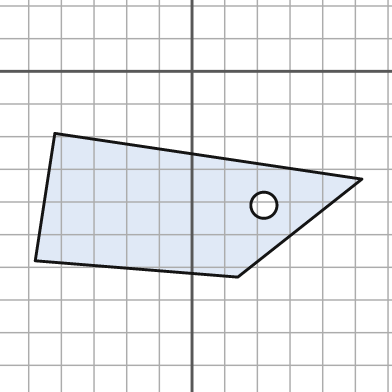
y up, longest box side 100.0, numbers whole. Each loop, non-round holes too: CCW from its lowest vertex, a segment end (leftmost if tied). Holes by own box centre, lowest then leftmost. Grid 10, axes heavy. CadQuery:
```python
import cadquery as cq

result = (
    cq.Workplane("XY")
    .moveTo(14.0, -63.0)
    .lineTo(52.0, -33.0)
    .lineTo(-42.0, -19.0)
    .lineTo(-48.0, -58.0)
    .close()
    .moveTo(22.0, -41.0)
    .circle(4.0)
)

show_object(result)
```